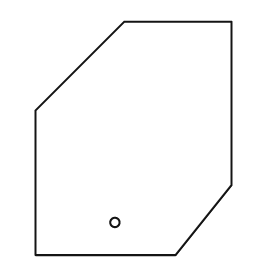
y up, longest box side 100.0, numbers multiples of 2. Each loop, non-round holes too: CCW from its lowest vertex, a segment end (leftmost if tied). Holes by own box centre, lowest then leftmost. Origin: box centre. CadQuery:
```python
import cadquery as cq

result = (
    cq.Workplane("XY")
    .moveTo(-42.0, -50.0)
    .lineTo(18.0, -50.0)
    .lineTo(42.0, -20.0)
    .lineTo(42.0, 50.0)
    .lineTo(-4.0, 50.0)
    .lineTo(-42.0, 12.0)
    .close()
    .moveTo(-8.0, -36.0)
    .circle(2.0)
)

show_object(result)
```